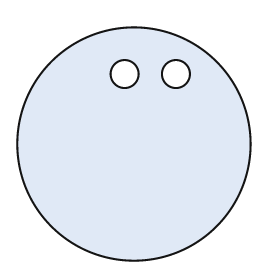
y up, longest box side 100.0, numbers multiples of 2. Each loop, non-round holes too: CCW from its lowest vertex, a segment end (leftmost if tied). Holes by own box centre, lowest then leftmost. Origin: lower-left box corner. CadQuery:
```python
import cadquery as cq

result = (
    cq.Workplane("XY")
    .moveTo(50.0, 50.0)
    .circle(50.0)
    .moveTo(46.0, 80.0)
    .circle(6.0)
    .moveTo(68.0, 80.0)
    .circle(6.0)
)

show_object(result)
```